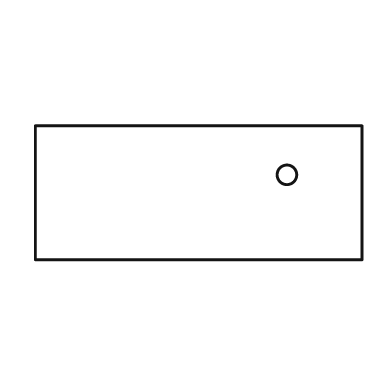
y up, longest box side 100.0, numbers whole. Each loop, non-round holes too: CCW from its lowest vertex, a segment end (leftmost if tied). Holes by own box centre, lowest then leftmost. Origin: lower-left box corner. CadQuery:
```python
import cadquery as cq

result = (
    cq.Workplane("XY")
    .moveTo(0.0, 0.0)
    .lineTo(100.0, 0.0)
    .lineTo(100.0, 41.0)
    .lineTo(0.0, 41.0)
    .close()
    .moveTo(77.0, 26.0)
    .circle(3.0)
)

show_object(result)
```